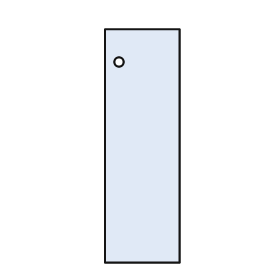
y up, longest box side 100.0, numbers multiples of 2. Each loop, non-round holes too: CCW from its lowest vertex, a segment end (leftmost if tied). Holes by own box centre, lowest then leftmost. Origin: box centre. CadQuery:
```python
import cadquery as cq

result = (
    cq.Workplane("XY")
    .moveTo(-16.0, -50.0)
    .lineTo(16.0, -50.0)
    .lineTo(16.0, 50.0)
    .lineTo(-16.0, 50.0)
    .close()
    .moveTo(-10.0, 36.0)
    .circle(2.0)
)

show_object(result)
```